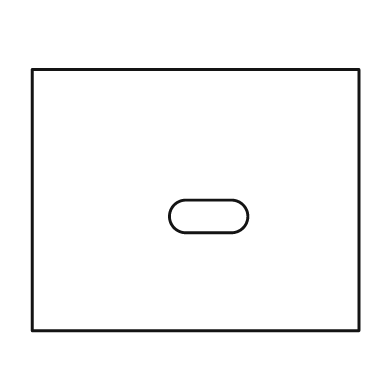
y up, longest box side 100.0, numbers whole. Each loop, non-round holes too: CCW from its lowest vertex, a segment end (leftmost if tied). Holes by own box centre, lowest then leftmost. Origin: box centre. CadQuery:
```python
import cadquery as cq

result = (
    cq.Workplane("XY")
    .moveTo(-50.0, -40.0)
    .lineTo(50.0, -40.0)
    .lineTo(50.0, 40.0)
    .lineTo(-50.0, 40.0)
    .close()
    .moveTo(-3.0, -10.0)
    .lineTo(11.0, -10.0)
    .threePointArc((16.0, -5.0), (11.0, 0.0))
    .lineTo(-3.0, 0.0)
    .threePointArc((-8.0, -5.0), (-3.0, -10.0))
    .close()
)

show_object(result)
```